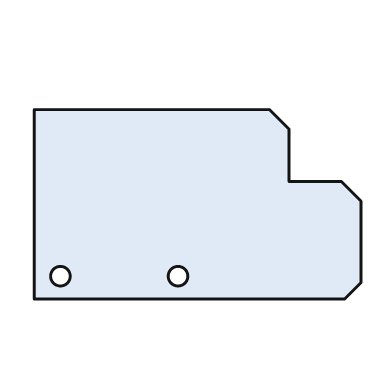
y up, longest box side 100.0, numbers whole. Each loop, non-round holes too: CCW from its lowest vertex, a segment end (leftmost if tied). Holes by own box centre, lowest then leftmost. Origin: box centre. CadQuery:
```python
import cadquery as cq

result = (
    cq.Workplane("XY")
    .moveTo(-50.0, -29.0)
    .lineTo(45.0, -29.0)
    .lineTo(50.0, -24.0)
    .lineTo(50.0, 1.0)
    .lineTo(44.0, 7.0)
    .lineTo(28.0, 7.0)
    .lineTo(28.0, 23.0)
    .lineTo(22.0, 29.0)
    .lineTo(-50.0, 29.0)
    .close()
    .moveTo(-42.0, -22.0)
    .circle(3.0)
    .moveTo(-6.0, -22.0)
    .circle(3.0)
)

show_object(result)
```